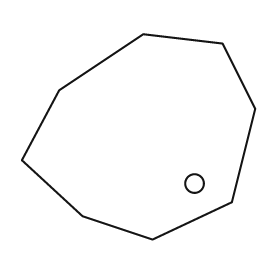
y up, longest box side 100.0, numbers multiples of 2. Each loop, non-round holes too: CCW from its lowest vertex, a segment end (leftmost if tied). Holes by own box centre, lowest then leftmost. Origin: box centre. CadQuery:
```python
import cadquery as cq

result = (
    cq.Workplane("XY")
    .moveTo(6.0, -44.0)
    .lineTo(40.0, -28.0)
    .lineTo(50.0, 12.0)
    .lineTo(36.0, 40.0)
    .lineTo(2.0, 44.0)
    .lineTo(-34.0, 20.0)
    .lineTo(-50.0, -10.0)
    .lineTo(-24.0, -34.0)
    .close()
    .moveTo(24.0, -20.0)
    .circle(4.0)
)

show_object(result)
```